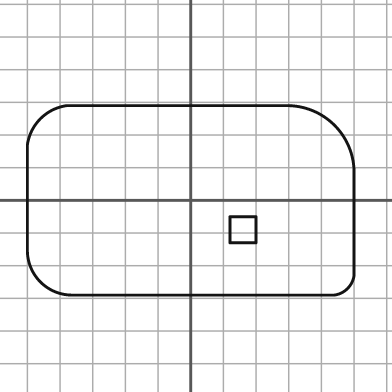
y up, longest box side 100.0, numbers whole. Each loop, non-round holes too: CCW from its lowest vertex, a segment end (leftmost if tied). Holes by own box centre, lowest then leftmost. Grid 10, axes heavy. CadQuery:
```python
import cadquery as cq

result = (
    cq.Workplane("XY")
    .moveTo(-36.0, -29.0)
    .lineTo(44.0, -29.0)
    .threePointArc((48.0, -27.0), (50.0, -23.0))
    .lineTo(50.0, 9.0)
    .threePointArc((44.0, 23.0), (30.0, 29.0))
    .lineTo(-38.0, 29.0)
    .threePointArc((-46.0, 25.0), (-50.0, 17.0))
    .lineTo(-50.0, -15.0)
    .threePointArc((-46.0, -25.0), (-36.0, -29.0))
    .close()
    .moveTo(12.0, -13.0)
    .lineTo(20.0, -13.0)
    .lineTo(20.0, -5.0)
    .lineTo(12.0, -5.0)
    .close()
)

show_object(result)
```